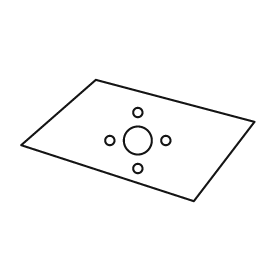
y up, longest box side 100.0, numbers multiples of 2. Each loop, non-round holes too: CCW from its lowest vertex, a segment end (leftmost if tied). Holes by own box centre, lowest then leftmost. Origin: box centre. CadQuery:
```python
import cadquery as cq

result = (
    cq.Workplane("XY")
    .moveTo(24.0, -26.0)
    .lineTo(50.0, 8.0)
    .lineTo(-18.0, 26.0)
    .lineTo(-50.0, -2.0)
    .close()
    .moveTo(0.0, -12.0)
    .circle(2.0)
    .moveTo(-12.0, 0.0)
    .circle(2.0)
    .moveTo(0.0, 0.0)
    .circle(6.0)
    .moveTo(12.0, 0.0)
    .circle(2.0)
    .moveTo(0.0, 12.0)
    .circle(2.0)
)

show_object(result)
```